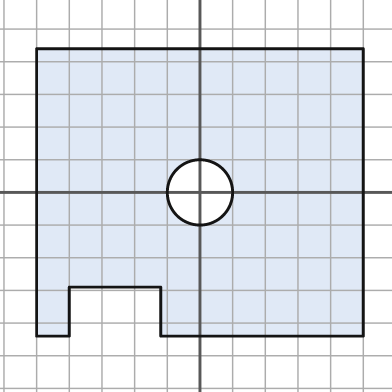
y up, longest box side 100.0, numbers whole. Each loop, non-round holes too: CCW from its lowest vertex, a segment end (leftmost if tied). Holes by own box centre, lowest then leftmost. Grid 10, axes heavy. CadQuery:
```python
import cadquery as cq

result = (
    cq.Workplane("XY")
    .moveTo(-50.0, -44.0)
    .lineTo(-40.0, -44.0)
    .lineTo(-40.0, -29.0)
    .lineTo(-12.0, -29.0)
    .lineTo(-12.0, -44.0)
    .lineTo(50.0, -44.0)
    .lineTo(50.0, 44.0)
    .lineTo(-50.0, 44.0)
    .close()
    .moveTo(0.0, 0.0)
    .circle(10.0)
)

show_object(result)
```